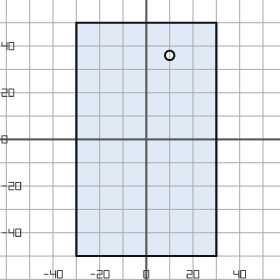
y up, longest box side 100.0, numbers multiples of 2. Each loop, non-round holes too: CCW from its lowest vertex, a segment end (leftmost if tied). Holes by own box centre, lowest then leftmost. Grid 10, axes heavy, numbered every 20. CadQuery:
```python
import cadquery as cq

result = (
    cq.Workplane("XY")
    .moveTo(-30.0, -50.0)
    .lineTo(30.0, -50.0)
    .lineTo(30.0, 50.0)
    .lineTo(-30.0, 50.0)
    .close()
    .moveTo(10.0, 36.0)
    .circle(2.0)
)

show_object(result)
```